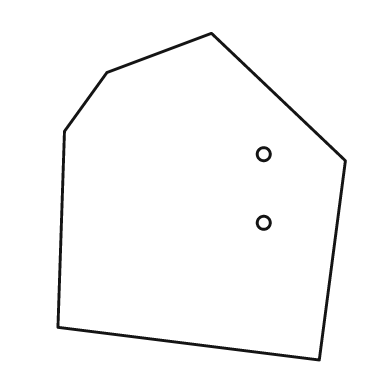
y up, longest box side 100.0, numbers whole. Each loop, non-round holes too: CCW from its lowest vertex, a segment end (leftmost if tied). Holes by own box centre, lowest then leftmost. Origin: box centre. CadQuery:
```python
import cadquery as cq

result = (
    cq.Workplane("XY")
    .moveTo(36.0, -50.0)
    .lineTo(44.0, 11.0)
    .lineTo(3.0, 50.0)
    .lineTo(-29.0, 38.0)
    .lineTo(-42.0, 20.0)
    .lineTo(-44.0, -40.0)
    .close()
    .moveTo(19.0, -8.0)
    .circle(2.0)
    .moveTo(19.0, 13.0)
    .circle(2.0)
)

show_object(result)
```